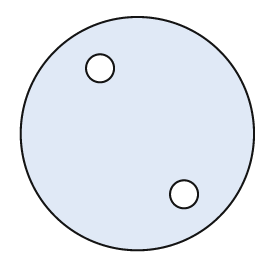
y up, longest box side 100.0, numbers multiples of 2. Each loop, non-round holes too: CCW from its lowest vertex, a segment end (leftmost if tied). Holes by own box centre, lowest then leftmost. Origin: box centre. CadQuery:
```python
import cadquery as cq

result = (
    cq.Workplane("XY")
    .moveTo(0.0, 0.0)
    .circle(50.0)
    .moveTo(20.0, -26.0)
    .circle(6.0)
    .moveTo(-16.0, 28.0)
    .circle(6.0)
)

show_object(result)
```